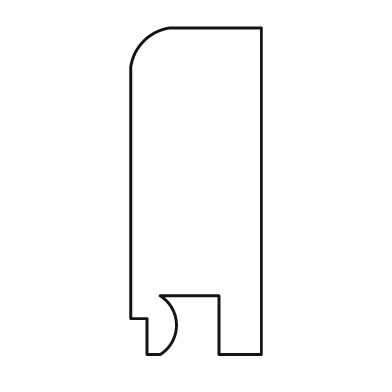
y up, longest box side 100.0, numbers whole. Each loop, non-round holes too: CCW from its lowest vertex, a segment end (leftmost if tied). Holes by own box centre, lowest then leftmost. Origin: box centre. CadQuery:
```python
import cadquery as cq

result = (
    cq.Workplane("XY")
    .moveTo(-15.0, -50.0)
    .lineTo(-11.0, -50.0)
    .threePointArc((-6.0, -41.0), (-11.0, -32.0))
    .lineTo(7.0, -32.0)
    .lineTo(7.0, -50.0)
    .lineTo(20.0, -50.0)
    .lineTo(20.0, 50.0)
    .lineTo(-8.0, 50.0)
    .threePointArc((-16.0, 46.0), (-20.0, 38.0))
    .lineTo(-20.0, -39.0)
    .lineTo(-15.0, -39.0)
    .close()
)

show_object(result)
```